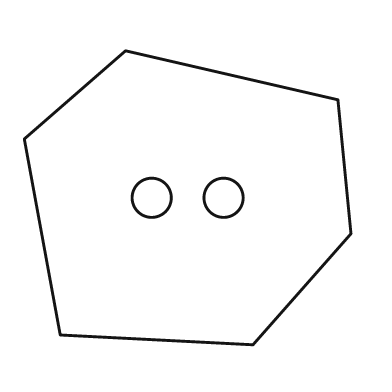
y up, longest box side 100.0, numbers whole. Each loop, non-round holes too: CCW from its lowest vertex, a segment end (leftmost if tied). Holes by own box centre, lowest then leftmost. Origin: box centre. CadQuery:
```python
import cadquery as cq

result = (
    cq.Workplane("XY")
    .moveTo(20.0, -45.0)
    .lineTo(50.0, -11.0)
    .lineTo(46.0, 30.0)
    .lineTo(-19.0, 45.0)
    .lineTo(-50.0, 18.0)
    .lineTo(-39.0, -42.0)
    .close()
    .moveTo(-11.0, 0.0)
    .circle(6.0)
    .moveTo(11.0, 0.0)
    .circle(6.0)
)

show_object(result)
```